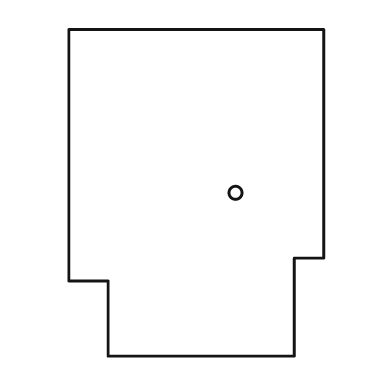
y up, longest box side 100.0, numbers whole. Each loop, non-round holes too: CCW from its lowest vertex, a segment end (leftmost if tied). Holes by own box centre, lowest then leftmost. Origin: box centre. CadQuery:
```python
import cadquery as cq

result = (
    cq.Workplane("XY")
    .moveTo(-27.0, -50.0)
    .lineTo(30.0, -50.0)
    .lineTo(30.0, -20.0)
    .lineTo(39.0, -20.0)
    .lineTo(39.0, 50.0)
    .lineTo(-39.0, 50.0)
    .lineTo(-39.0, -27.0)
    .lineTo(-27.0, -27.0)
    .close()
    .moveTo(12.0, 0.0)
    .circle(2.0)
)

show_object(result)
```